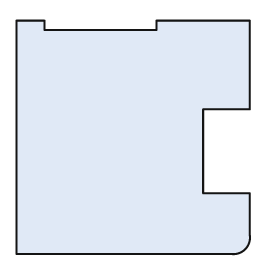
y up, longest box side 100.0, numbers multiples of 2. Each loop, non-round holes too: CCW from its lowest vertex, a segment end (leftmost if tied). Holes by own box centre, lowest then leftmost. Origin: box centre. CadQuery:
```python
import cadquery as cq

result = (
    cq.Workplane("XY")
    .moveTo(-50.0, -50.0)
    .lineTo(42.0, -50.0)
    .threePointArc((48.0, -48.0), (50.0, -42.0))
    .lineTo(50.0, -24.0)
    .lineTo(30.0, -24.0)
    .lineTo(30.0, 12.0)
    .lineTo(50.0, 12.0)
    .lineTo(50.0, 50.0)
    .lineTo(10.0, 50.0)
    .lineTo(10.0, 46.0)
    .lineTo(-38.0, 46.0)
    .lineTo(-38.0, 50.0)
    .lineTo(-50.0, 50.0)
    .close()
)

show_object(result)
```